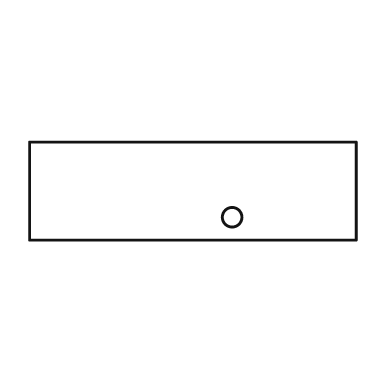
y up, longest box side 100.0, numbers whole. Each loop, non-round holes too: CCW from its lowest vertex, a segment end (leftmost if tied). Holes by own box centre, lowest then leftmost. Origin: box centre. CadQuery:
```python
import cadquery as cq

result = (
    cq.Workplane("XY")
    .moveTo(-50.0, -15.0)
    .lineTo(50.0, -15.0)
    .lineTo(50.0, 15.0)
    .lineTo(-50.0, 15.0)
    .close()
    .moveTo(12.0, -8.0)
    .circle(3.0)
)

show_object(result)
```